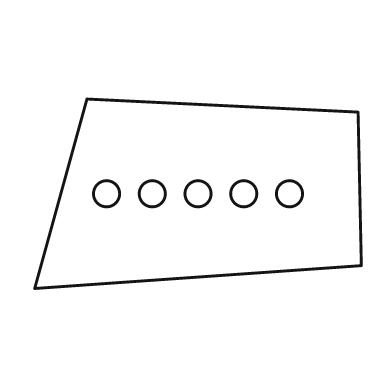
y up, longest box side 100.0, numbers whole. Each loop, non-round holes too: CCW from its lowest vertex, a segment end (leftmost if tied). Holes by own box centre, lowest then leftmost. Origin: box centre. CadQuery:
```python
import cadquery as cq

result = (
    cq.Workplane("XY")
    .moveTo(-50.0, -29.0)
    .lineTo(50.0, -22.0)
    .lineTo(49.0, 25.0)
    .lineTo(-34.0, 29.0)
    .close()
    .moveTo(-28.0, 0.0)
    .circle(4.0)
    .moveTo(-14.0, 0.0)
    .circle(4.0)
    .moveTo(0.0, 0.0)
    .circle(4.0)
    .moveTo(14.0, 0.0)
    .circle(4.0)
    .moveTo(28.0, 0.0)
    .circle(4.0)
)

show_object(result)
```